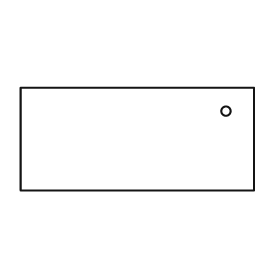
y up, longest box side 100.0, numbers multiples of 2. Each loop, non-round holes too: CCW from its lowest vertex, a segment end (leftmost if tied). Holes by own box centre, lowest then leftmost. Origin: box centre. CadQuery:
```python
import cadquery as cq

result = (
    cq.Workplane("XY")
    .moveTo(-50.0, -22.0)
    .lineTo(50.0, -22.0)
    .lineTo(50.0, 22.0)
    .lineTo(-50.0, 22.0)
    .close()
    .moveTo(38.0, 12.0)
    .circle(2.0)
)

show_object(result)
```